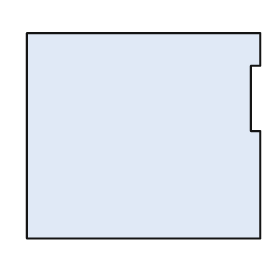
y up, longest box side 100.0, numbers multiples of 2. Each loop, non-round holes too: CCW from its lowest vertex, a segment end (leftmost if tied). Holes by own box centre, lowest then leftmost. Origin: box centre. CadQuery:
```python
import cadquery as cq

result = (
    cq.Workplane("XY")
    .moveTo(-50.0, -44.0)
    .lineTo(50.0, -44.0)
    .lineTo(50.0, 2.0)
    .lineTo(46.0, 2.0)
    .lineTo(46.0, 30.0)
    .lineTo(50.0, 30.0)
    .lineTo(50.0, 44.0)
    .lineTo(-50.0, 44.0)
    .close()
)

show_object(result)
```